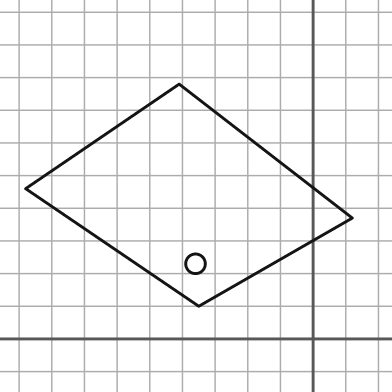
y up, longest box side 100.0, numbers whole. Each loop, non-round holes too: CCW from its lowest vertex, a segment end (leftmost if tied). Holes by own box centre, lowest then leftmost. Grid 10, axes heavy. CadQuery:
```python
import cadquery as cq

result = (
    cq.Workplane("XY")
    .moveTo(-35.0, 10.0)
    .lineTo(12.0, 37.0)
    .lineTo(-41.0, 78.0)
    .lineTo(-88.0, 46.0)
    .close()
    .moveTo(-36.0, 23.0)
    .circle(3.0)
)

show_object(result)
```